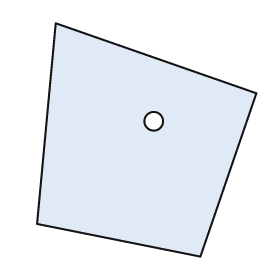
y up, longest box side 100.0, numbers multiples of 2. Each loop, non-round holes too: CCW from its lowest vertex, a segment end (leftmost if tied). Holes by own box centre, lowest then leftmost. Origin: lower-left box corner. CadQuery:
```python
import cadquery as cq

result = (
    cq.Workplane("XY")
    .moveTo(70.0, 0.0)
    .lineTo(94.0, 70.0)
    .lineTo(8.0, 100.0)
    .lineTo(0.0, 14.0)
    .close()
    .moveTo(50.0, 58.0)
    .circle(4.0)
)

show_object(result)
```